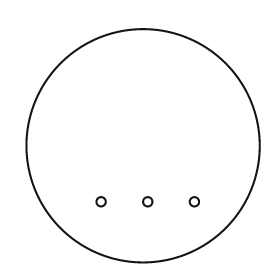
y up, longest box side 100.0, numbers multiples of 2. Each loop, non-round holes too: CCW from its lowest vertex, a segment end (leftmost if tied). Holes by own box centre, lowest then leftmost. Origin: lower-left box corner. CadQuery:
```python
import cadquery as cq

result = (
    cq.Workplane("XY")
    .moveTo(50.0, 50.0)
    .circle(50.0)
    .moveTo(32.0, 26.0)
    .circle(2.0)
    .moveTo(52.0, 26.0)
    .circle(2.0)
    .moveTo(72.0, 26.0)
    .circle(2.0)
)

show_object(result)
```